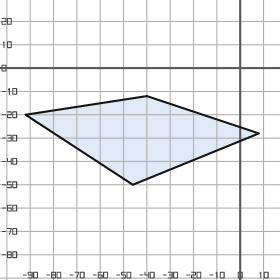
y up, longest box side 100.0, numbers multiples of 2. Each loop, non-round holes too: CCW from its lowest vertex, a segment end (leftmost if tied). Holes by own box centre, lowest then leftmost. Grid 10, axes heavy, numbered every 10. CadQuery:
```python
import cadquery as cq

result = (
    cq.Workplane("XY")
    .moveTo(-46.0, -50.0)
    .lineTo(8.0, -28.0)
    .lineTo(-40.0, -12.0)
    .lineTo(-92.0, -20.0)
    .close()
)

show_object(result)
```